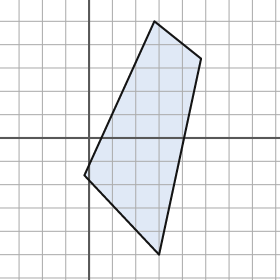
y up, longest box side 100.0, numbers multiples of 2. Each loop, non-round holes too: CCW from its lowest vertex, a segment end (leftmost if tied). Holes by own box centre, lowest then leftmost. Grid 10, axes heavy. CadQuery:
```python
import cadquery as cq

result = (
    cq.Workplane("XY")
    .moveTo(30.0, -50.0)
    .lineTo(48.0, 34.0)
    .lineTo(28.0, 50.0)
    .lineTo(-2.0, -16.0)
    .close()
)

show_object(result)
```